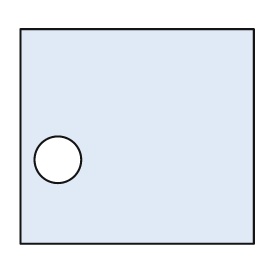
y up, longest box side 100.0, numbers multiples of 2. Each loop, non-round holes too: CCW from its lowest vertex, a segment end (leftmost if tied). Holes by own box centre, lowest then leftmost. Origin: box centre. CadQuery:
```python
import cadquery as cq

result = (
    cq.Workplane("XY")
    .moveTo(-50.0, -46.0)
    .lineTo(50.0, -46.0)
    .lineTo(50.0, 46.0)
    .lineTo(-50.0, 46.0)
    .close()
    .moveTo(-34.0, -10.0)
    .circle(10.0)
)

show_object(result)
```